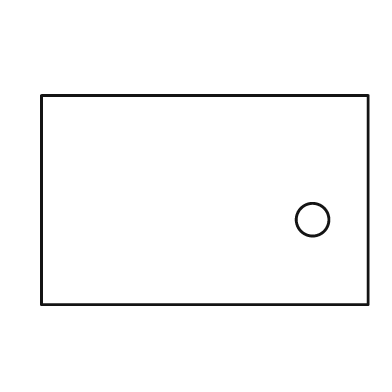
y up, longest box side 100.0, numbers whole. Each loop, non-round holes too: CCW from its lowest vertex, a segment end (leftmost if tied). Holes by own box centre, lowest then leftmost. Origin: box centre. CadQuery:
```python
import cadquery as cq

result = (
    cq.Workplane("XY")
    .moveTo(-50.0, -32.0)
    .lineTo(50.0, -32.0)
    .lineTo(50.0, 32.0)
    .lineTo(-50.0, 32.0)
    .close()
    .moveTo(33.0, -6.0)
    .circle(5.0)
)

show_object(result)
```